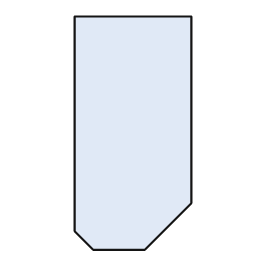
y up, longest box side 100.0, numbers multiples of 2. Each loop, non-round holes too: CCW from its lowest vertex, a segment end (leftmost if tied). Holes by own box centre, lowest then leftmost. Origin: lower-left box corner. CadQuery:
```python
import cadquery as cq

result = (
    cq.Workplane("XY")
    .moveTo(8.0, 0.0)
    .lineTo(30.0, 0.0)
    .lineTo(50.0, 20.0)
    .lineTo(50.0, 100.0)
    .lineTo(0.0, 100.0)
    .lineTo(0.0, 8.0)
    .close()
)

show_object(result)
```